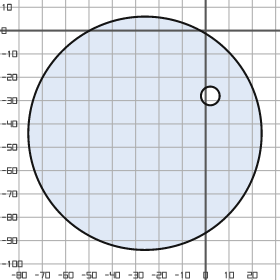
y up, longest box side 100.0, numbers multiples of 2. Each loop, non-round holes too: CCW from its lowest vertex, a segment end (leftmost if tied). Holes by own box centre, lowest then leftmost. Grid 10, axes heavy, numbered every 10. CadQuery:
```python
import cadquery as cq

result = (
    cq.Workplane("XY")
    .moveTo(-26.0, -44.0)
    .circle(50.0)
    .moveTo(2.0, -28.0)
    .circle(4.0)
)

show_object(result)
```